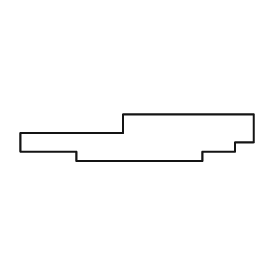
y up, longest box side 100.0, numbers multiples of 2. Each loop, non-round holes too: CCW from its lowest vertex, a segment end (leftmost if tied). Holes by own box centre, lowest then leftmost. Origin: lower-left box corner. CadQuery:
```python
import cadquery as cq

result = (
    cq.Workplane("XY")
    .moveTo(24.0, 0.0)
    .lineTo(78.0, 0.0)
    .lineTo(78.0, 4.0)
    .lineTo(92.0, 4.0)
    .lineTo(92.0, 8.0)
    .lineTo(100.0, 8.0)
    .lineTo(100.0, 20.0)
    .lineTo(44.0, 20.0)
    .lineTo(44.0, 12.0)
    .lineTo(0.0, 12.0)
    .lineTo(0.0, 4.0)
    .lineTo(24.0, 4.0)
    .close()
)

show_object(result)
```